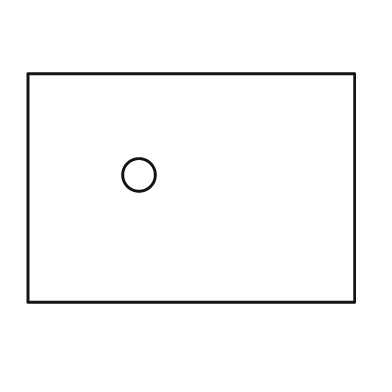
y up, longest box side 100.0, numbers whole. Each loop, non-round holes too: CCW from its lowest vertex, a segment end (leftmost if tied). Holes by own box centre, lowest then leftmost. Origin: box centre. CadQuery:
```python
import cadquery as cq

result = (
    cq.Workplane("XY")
    .moveTo(-50.0, -35.0)
    .lineTo(50.0, -35.0)
    .lineTo(50.0, 35.0)
    .lineTo(-50.0, 35.0)
    .close()
    .moveTo(-16.0, 4.0)
    .circle(5.0)
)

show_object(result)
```